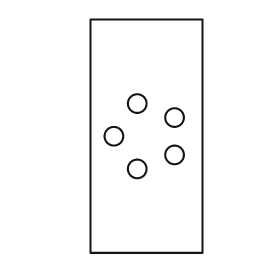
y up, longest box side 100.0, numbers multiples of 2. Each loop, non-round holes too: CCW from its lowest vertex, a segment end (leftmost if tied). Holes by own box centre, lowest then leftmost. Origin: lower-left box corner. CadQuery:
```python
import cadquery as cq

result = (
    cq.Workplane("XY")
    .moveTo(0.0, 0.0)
    .lineTo(48.0, 0.0)
    .lineTo(48.0, 100.0)
    .lineTo(0.0, 100.0)
    .close()
    .moveTo(20.0, 36.0)
    .circle(4.0)
    .moveTo(36.0, 42.0)
    .circle(4.0)
    .moveTo(10.0, 50.0)
    .circle(4.0)
    .moveTo(36.0, 58.0)
    .circle(4.0)
    .moveTo(20.0, 64.0)
    .circle(4.0)
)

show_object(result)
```